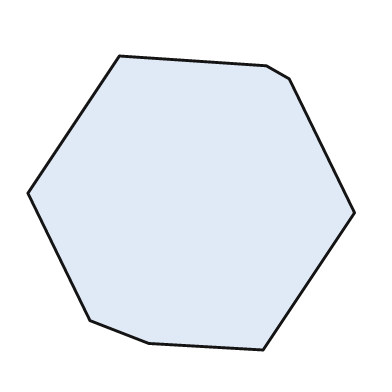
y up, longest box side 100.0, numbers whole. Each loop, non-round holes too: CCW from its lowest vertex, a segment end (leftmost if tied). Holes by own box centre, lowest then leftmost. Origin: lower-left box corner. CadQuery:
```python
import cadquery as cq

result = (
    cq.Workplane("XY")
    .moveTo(72.0, 0.0)
    .lineTo(100.0, 42.0)
    .lineTo(80.0, 83.0)
    .lineTo(73.0, 87.0)
    .lineTo(28.0, 90.0)
    .lineTo(0.0, 48.0)
    .lineTo(19.0, 9.0)
    .lineTo(37.0, 2.0)
    .close()
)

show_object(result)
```